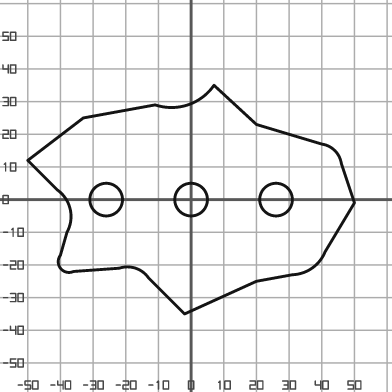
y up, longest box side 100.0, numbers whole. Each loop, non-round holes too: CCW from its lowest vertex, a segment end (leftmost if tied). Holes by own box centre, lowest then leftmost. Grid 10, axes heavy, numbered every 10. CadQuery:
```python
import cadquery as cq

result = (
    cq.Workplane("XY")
    .moveTo(-2.0, -35.0)
    .lineTo(20.0, -25.0)
    .lineTo(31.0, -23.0)
    .threePointArc((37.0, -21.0), (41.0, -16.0))
    .lineTo(50.0, -1.0)
    .lineTo(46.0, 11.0)
    .threePointArc((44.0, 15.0), (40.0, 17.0))
    .lineTo(20.0, 23.0)
    .lineTo(7.0, 35.0)
    .threePointArc((-1.0, 29.0), (-11.0, 29.0))
    .lineTo(-33.0, 25.0)
    .lineTo(-50.0, 12.0)
    .lineTo(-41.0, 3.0)
    .threePointArc((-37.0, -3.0), (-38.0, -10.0))
    .lineTo(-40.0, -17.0)
    .threePointArc((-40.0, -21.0), (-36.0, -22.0))
    .lineTo(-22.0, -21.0)
    .threePointArc((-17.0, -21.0), (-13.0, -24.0))
    .close()
    .moveTo(-26.0, 0.0)
    .circle(5.0)
    .moveTo(0.0, 0.0)
    .circle(5.0)
    .moveTo(26.0, 0.0)
    .circle(5.0)
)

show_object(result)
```